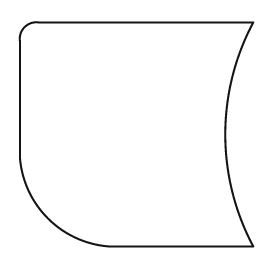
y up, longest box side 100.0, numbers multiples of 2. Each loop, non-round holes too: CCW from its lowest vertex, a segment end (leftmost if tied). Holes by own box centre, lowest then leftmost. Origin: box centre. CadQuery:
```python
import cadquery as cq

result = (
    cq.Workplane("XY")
    .moveTo(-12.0, -48.0)
    .lineTo(50.0, -48.0)
    .threePointArc((38.0, 0.0), (50.0, 48.0))
    .lineTo(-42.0, 48.0)
    .threePointArc((-48.0, 46.0), (-50.0, 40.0))
    .lineTo(-50.0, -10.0)
    .threePointArc((-38.0, -36.0), (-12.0, -48.0))
    .close()
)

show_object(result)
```